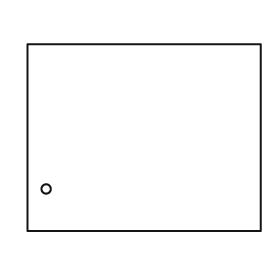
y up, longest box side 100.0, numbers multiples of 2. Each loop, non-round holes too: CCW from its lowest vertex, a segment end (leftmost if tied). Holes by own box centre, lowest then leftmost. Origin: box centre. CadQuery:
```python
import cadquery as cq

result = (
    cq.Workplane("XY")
    .moveTo(-50.0, -40.0)
    .lineTo(50.0, -40.0)
    .lineTo(50.0, 40.0)
    .lineTo(-50.0, 40.0)
    .close()
    .moveTo(-42.0, -22.0)
    .circle(2.0)
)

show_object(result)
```